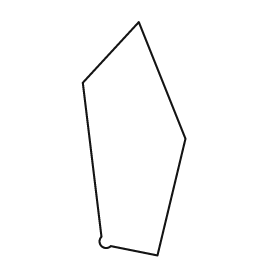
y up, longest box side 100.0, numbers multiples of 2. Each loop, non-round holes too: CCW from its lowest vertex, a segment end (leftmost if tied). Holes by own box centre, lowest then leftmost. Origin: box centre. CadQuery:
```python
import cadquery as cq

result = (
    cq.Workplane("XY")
    .moveTo(10.0, -50.0)
    .lineTo(22.0, 0.0)
    .lineTo(2.0, 50.0)
    .lineTo(-22.0, 24.0)
    .lineTo(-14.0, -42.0)
    .threePointArc((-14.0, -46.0), (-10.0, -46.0))
    .close()
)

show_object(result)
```